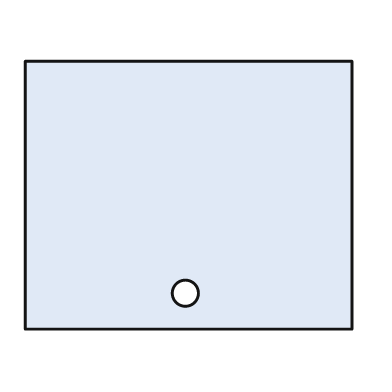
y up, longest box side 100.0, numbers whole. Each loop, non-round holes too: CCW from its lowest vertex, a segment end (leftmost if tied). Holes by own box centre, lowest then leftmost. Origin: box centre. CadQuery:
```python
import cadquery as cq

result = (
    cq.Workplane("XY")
    .moveTo(-50.0, -41.0)
    .lineTo(50.0, -41.0)
    .lineTo(50.0, 41.0)
    .lineTo(-50.0, 41.0)
    .close()
    .moveTo(-1.0, -30.0)
    .circle(4.0)
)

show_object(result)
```